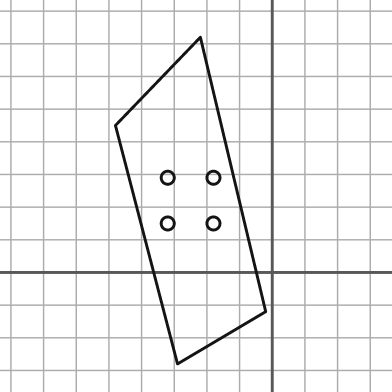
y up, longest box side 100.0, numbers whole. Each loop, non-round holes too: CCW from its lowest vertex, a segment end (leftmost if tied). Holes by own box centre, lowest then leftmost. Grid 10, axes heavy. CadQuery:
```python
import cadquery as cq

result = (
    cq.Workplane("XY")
    .moveTo(-29.0, -28.0)
    .lineTo(-2.0, -12.0)
    .lineTo(-22.0, 72.0)
    .lineTo(-48.0, 45.0)
    .close()
    .moveTo(-32.0, 15.0)
    .circle(2.0)
    .moveTo(-18.0, 15.0)
    .circle(2.0)
    .moveTo(-32.0, 29.0)
    .circle(2.0)
    .moveTo(-18.0, 29.0)
    .circle(2.0)
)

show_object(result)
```